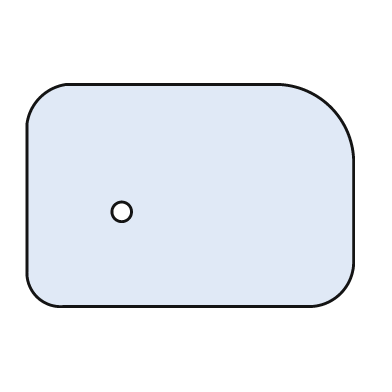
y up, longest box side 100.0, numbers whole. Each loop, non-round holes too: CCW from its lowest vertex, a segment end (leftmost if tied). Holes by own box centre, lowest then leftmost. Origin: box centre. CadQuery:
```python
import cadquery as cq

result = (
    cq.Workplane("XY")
    .moveTo(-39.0, -34.0)
    .lineTo(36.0, -34.0)
    .threePointArc((46.0, -30.0), (50.0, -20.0))
    .lineTo(50.0, 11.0)
    .threePointArc((43.0, 27.0), (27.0, 34.0))
    .lineTo(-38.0, 34.0)
    .threePointArc((-46.0, 30.0), (-50.0, 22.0))
    .lineTo(-50.0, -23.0)
    .threePointArc((-47.0, -31.0), (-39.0, -34.0))
    .close()
    .moveTo(-21.0, -5.0)
    .circle(3.0)
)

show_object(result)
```